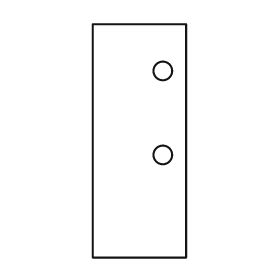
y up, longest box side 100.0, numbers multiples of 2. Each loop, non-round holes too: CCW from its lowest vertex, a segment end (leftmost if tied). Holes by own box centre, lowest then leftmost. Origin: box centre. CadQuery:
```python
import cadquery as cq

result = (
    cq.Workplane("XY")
    .moveTo(-20.0, -50.0)
    .lineTo(20.0, -50.0)
    .lineTo(20.0, 50.0)
    .lineTo(-20.0, 50.0)
    .close()
    .moveTo(10.0, -6.0)
    .circle(4.0)
    .moveTo(10.0, 30.0)
    .circle(4.0)
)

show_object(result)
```